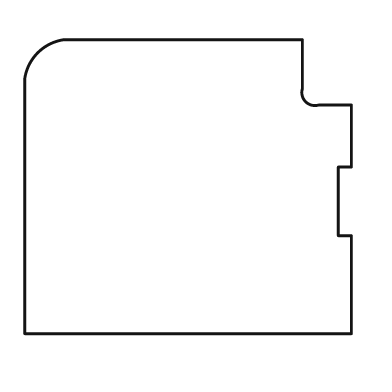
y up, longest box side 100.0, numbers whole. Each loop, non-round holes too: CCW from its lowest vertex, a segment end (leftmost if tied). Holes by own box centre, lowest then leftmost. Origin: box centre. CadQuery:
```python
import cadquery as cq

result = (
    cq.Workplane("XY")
    .moveTo(-50.0, -45.0)
    .lineTo(50.0, -45.0)
    .lineTo(50.0, -15.0)
    .lineTo(46.0, -15.0)
    .lineTo(46.0, 6.0)
    .lineTo(50.0, 6.0)
    .lineTo(50.0, 25.0)
    .lineTo(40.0, 25.0)
    .threePointArc((36.0, 26.0), (35.0, 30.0))
    .lineTo(35.0, 45.0)
    .lineTo(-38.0, 45.0)
    .threePointArc((-46.0, 41.0), (-50.0, 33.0))
    .close()
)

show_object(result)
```